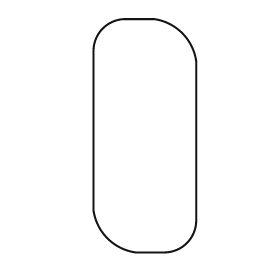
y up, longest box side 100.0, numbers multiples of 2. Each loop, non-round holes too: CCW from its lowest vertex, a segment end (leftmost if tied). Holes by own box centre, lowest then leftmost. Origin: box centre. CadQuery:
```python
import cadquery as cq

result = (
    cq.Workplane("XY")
    .moveTo(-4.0, -50.0)
    .lineTo(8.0, -50.0)
    .threePointArc((18.0, -46.0), (22.0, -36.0))
    .lineTo(22.0, 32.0)
    .threePointArc((16.0, 44.0), (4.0, 50.0))
    .lineTo(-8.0, 50.0)
    .threePointArc((-18.0, 46.0), (-22.0, 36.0))
    .lineTo(-22.0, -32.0)
    .threePointArc((-16.0, -44.0), (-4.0, -50.0))
    .close()
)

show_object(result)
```